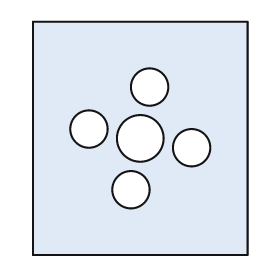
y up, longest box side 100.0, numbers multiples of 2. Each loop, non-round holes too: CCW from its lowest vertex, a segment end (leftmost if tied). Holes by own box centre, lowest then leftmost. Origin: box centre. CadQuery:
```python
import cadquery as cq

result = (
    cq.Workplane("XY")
    .moveTo(-46.0, -50.0)
    .lineTo(46.0, -50.0)
    .lineTo(46.0, 50.0)
    .lineTo(-46.0, 50.0)
    .close()
    .moveTo(-4.0, -22.0)
    .circle(8.0)
    .moveTo(22.0, -4.0)
    .circle(8.0)
    .moveTo(0.0, 0.0)
    .circle(10.0)
    .moveTo(-22.0, 4.0)
    .circle(8.0)
    .moveTo(4.0, 22.0)
    .circle(8.0)
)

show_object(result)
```